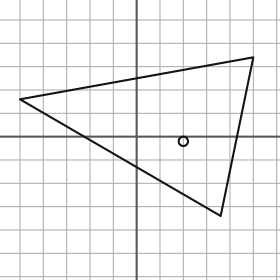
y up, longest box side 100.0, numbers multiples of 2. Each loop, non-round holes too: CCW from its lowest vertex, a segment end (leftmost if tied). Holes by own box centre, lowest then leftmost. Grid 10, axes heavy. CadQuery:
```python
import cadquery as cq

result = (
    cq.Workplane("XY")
    .moveTo(36.0, -34.0)
    .lineTo(50.0, 34.0)
    .lineTo(-50.0, 16.0)
    .close()
    .moveTo(20.0, -2.0)
    .circle(2.0)
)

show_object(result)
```